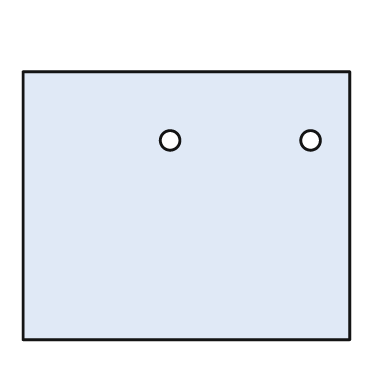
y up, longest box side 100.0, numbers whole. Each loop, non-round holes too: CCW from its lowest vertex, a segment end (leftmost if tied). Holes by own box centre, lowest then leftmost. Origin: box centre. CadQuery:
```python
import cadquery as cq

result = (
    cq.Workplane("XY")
    .moveTo(-50.0, -41.0)
    .lineTo(50.0, -41.0)
    .lineTo(50.0, 41.0)
    .lineTo(-50.0, 41.0)
    .close()
    .moveTo(-5.0, 20.0)
    .circle(3.0)
    .moveTo(38.0, 20.0)
    .circle(3.0)
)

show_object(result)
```